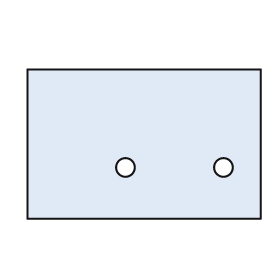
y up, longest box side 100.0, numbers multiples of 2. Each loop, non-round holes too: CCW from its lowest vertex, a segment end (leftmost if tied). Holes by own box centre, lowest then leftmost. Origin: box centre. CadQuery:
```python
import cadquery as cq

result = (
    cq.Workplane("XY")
    .moveTo(-50.0, -32.0)
    .lineTo(50.0, -32.0)
    .lineTo(50.0, 32.0)
    .lineTo(-50.0, 32.0)
    .close()
    .moveTo(-8.0, -10.0)
    .circle(4.0)
    .moveTo(34.0, -10.0)
    .circle(4.0)
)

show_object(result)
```